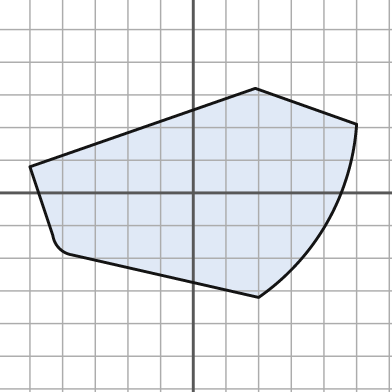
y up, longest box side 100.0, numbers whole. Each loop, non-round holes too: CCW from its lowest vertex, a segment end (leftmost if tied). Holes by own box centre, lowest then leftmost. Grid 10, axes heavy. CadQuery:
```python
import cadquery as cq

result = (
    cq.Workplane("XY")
    .moveTo(20.0, -32.0)
    .threePointArc((41.0, -9.0), (50.0, 21.0))
    .lineTo(19.0, 32.0)
    .lineTo(-50.0, 8.0)
    .lineTo(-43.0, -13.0)
    .threePointArc((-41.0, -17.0), (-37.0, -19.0))
    .close()
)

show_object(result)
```